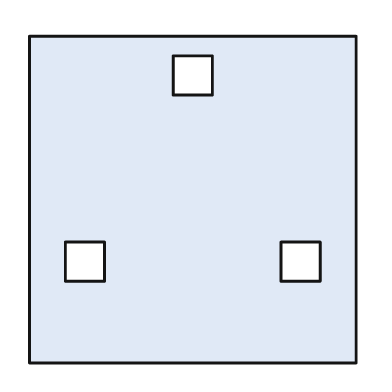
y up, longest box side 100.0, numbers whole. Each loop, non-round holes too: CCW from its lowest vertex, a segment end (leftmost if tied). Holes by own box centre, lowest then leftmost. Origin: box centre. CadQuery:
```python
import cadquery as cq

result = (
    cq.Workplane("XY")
    .moveTo(-50.0, -50.0)
    .lineTo(50.0, -50.0)
    .lineTo(50.0, 50.0)
    .lineTo(-50.0, 50.0)
    .close()
    .moveTo(-39.0, -25.0)
    .lineTo(-27.0, -25.0)
    .lineTo(-27.0, -13.0)
    .lineTo(-39.0, -13.0)
    .close()
    .moveTo(27.0, -25.0)
    .lineTo(39.0, -25.0)
    .lineTo(39.0, -13.0)
    .lineTo(27.0, -13.0)
    .close()
    .moveTo(-6.0, 32.0)
    .lineTo(6.0, 32.0)
    .lineTo(6.0, 44.0)
    .lineTo(-6.0, 44.0)
    .close()
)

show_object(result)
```